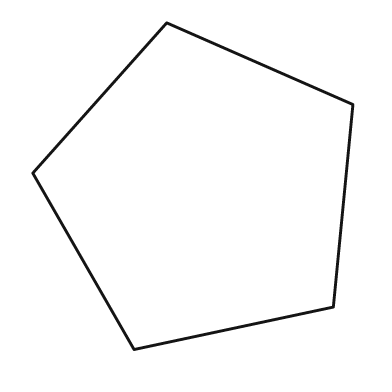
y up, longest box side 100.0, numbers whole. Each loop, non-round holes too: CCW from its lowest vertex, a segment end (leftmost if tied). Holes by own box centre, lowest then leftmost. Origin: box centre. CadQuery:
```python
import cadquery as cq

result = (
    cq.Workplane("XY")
    .moveTo(-18.0, -50.0)
    .lineTo(43.0, -37.0)
    .lineTo(49.0, 25.0)
    .lineTo(-8.0, 50.0)
    .lineTo(-49.0, 4.0)
    .close()
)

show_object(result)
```